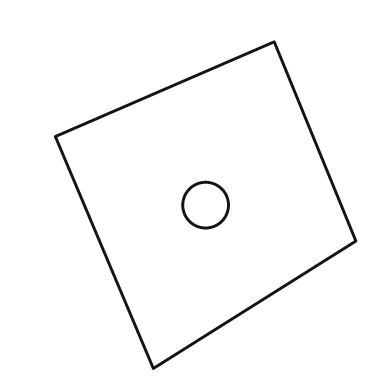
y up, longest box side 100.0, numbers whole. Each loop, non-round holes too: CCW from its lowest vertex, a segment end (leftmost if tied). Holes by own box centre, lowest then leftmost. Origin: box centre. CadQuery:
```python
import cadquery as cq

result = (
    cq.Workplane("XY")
    .moveTo(-16.0, -50.0)
    .lineTo(46.0, -11.0)
    .lineTo(21.0, 50.0)
    .lineTo(-46.0, 21.0)
    .close()
    .moveTo(0.0, 0.0)
    .circle(7.0)
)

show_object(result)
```